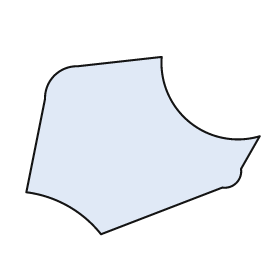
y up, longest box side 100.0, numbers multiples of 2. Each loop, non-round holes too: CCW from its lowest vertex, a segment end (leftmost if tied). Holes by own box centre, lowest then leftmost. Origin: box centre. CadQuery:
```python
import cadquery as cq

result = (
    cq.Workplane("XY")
    .moveTo(-18.0, -38.0)
    .lineTo(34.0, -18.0)
    .threePointArc((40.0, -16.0), (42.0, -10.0))
    .lineTo(50.0, 4.0)
    .threePointArc((20.0, 10.0), (8.0, 38.0))
    .lineTo(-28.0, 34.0)
    .threePointArc((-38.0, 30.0), (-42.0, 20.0))
    .lineTo(-50.0, -20.0)
    .threePointArc((-32.0, -26.0), (-18.0, -38.0))
    .close()
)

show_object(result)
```